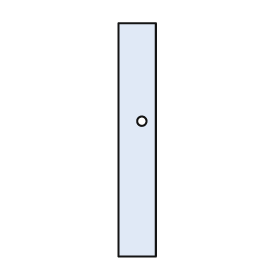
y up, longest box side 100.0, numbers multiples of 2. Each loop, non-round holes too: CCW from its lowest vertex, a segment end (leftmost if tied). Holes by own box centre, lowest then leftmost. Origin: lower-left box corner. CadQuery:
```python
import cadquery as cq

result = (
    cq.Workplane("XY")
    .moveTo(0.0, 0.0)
    .lineTo(16.0, 0.0)
    .lineTo(16.0, 100.0)
    .lineTo(0.0, 100.0)
    .close()
    .moveTo(10.0, 58.0)
    .circle(2.0)
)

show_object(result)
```